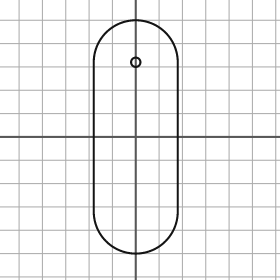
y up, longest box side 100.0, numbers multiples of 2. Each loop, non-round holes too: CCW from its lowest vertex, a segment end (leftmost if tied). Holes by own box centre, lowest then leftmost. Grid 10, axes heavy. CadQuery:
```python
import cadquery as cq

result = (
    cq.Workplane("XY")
    .moveTo(-18.0, -32.0)
    .threePointArc((0.0, -50.0), (18.0, -32.0))
    .lineTo(18.0, 32.0)
    .threePointArc((0.0, 50.0), (-18.0, 32.0))
    .close()
    .moveTo(0.0, 32.0)
    .circle(2.0)
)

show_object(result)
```